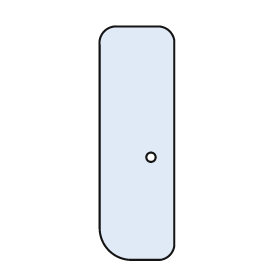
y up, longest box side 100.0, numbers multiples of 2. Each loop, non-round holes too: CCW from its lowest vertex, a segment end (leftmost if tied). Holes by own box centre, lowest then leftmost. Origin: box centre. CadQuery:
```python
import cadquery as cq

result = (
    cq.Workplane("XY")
    .moveTo(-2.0, -50.0)
    .lineTo(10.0, -50.0)
    .threePointArc((14.0, -48.0), (16.0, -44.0))
    .lineTo(16.0, 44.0)
    .threePointArc((14.0, 48.0), (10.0, 50.0))
    .lineTo(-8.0, 50.0)
    .threePointArc((-14.0, 48.0), (-16.0, 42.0))
    .lineTo(-16.0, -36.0)
    .threePointArc((-12.0, -46.0), (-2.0, -50.0))
    .close()
    .moveTo(6.0, -6.0)
    .circle(2.0)
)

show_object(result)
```